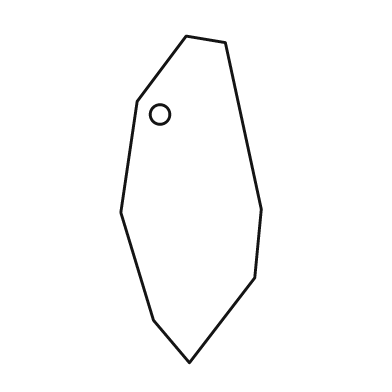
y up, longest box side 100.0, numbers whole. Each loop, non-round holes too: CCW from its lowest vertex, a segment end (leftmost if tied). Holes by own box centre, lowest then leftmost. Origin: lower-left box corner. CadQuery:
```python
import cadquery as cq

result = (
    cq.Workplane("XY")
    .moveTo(21.0, 0.0)
    .lineTo(41.0, 26.0)
    .lineTo(43.0, 47.0)
    .lineTo(32.0, 98.0)
    .lineTo(20.0, 100.0)
    .lineTo(5.0, 80.0)
    .lineTo(0.0, 46.0)
    .lineTo(10.0, 13.0)
    .close()
    .moveTo(12.0, 76.0)
    .circle(3.0)
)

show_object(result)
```